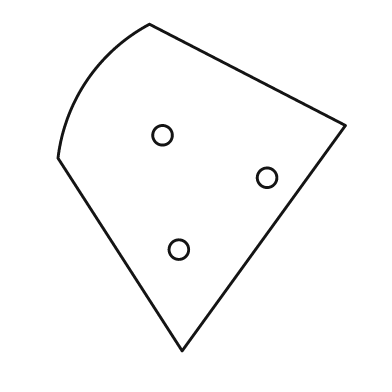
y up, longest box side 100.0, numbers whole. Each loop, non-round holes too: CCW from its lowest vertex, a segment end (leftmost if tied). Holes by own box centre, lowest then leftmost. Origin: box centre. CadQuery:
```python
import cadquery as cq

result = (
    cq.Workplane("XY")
    .moveTo(-6.0, -50.0)
    .lineTo(44.0, 19.0)
    .lineTo(-16.0, 50.0)
    .threePointArc((-35.0, 33.0), (-44.0, 9.0))
    .close()
    .moveTo(-7.0, -19.0)
    .circle(3.0)
    .moveTo(20.0, 3.0)
    .circle(3.0)
    .moveTo(-12.0, 16.0)
    .circle(3.0)
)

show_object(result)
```